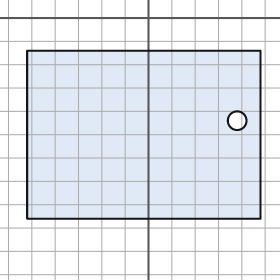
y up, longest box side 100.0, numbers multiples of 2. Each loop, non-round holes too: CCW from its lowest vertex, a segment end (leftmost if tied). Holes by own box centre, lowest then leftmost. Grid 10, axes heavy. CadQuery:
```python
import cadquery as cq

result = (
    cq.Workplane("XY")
    .moveTo(-52.0, -86.0)
    .lineTo(48.0, -86.0)
    .lineTo(48.0, -14.0)
    .lineTo(-52.0, -14.0)
    .close()
    .moveTo(38.0, -44.0)
    .circle(4.0)
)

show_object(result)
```